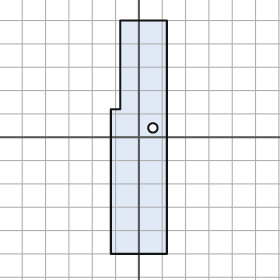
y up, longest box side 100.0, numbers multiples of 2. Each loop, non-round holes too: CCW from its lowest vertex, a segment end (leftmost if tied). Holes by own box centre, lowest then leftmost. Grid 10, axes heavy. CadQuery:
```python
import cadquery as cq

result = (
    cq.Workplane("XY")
    .moveTo(-12.0, -50.0)
    .lineTo(12.0, -50.0)
    .lineTo(12.0, 50.0)
    .lineTo(-8.0, 50.0)
    .lineTo(-8.0, 12.0)
    .lineTo(-12.0, 12.0)
    .close()
    .moveTo(6.0, 4.0)
    .circle(2.0)
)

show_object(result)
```